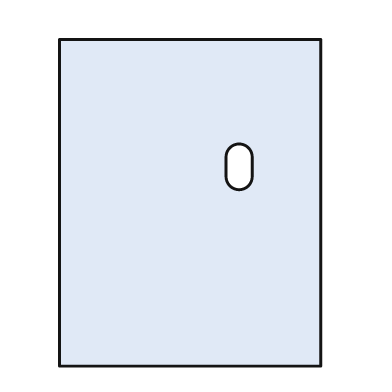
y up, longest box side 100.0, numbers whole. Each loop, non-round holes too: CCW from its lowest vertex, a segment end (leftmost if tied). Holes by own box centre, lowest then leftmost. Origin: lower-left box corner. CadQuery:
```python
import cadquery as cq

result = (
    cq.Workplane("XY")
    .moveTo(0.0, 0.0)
    .lineTo(80.0, 0.0)
    .lineTo(80.0, 100.0)
    .lineTo(0.0, 100.0)
    .close()
    .moveTo(51.0, 58.0)
    .threePointArc((55.0, 54.0), (59.0, 58.0))
    .lineTo(59.0, 64.0)
    .threePointArc((55.0, 68.0), (51.0, 64.0))
    .close()
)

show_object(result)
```